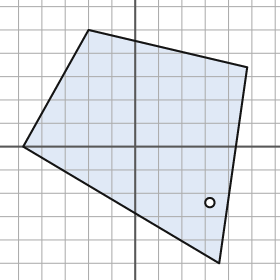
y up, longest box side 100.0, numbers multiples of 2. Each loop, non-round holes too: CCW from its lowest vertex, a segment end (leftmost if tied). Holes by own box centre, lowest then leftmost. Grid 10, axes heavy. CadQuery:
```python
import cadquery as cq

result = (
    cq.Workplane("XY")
    .moveTo(36.0, -50.0)
    .lineTo(48.0, 34.0)
    .lineTo(-20.0, 50.0)
    .lineTo(-48.0, 0.0)
    .close()
    .moveTo(32.0, -24.0)
    .circle(2.0)
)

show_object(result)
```